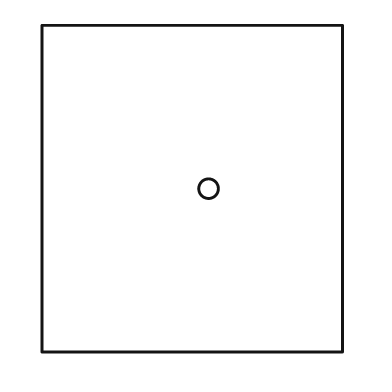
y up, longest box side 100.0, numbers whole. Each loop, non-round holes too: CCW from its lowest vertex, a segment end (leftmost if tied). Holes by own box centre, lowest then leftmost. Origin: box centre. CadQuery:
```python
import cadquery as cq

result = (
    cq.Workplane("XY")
    .moveTo(-46.0, -50.0)
    .lineTo(46.0, -50.0)
    .lineTo(46.0, 50.0)
    .lineTo(-46.0, 50.0)
    .close()
    .moveTo(5.0, 0.0)
    .circle(3.0)
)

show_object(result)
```